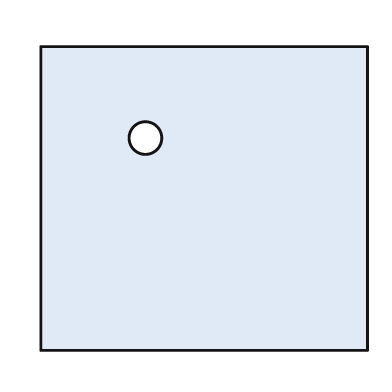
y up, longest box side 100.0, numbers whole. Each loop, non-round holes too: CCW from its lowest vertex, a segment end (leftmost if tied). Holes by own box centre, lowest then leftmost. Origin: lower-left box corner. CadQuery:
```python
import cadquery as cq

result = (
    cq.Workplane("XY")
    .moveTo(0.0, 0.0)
    .lineTo(100.0, 0.0)
    .lineTo(100.0, 93.0)
    .lineTo(0.0, 93.0)
    .close()
    .moveTo(32.0, 65.0)
    .circle(5.0)
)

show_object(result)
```